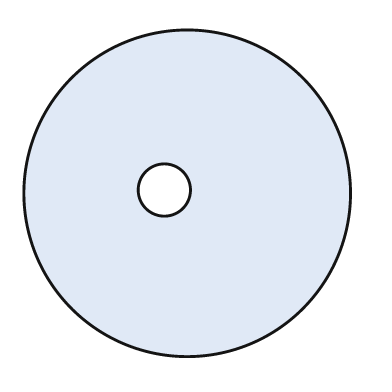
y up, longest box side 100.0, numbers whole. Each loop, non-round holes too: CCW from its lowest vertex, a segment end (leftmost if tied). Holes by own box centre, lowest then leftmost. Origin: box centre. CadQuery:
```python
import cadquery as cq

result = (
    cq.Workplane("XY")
    .moveTo(0.0, 0.0)
    .circle(50.0)
    .moveTo(-7.0, 1.0)
    .circle(8.0)
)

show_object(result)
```